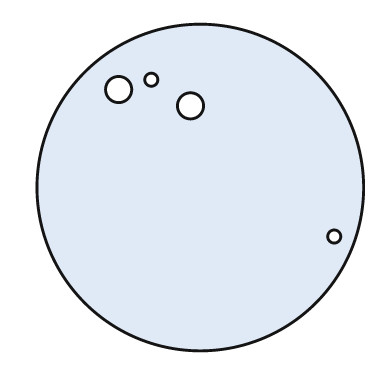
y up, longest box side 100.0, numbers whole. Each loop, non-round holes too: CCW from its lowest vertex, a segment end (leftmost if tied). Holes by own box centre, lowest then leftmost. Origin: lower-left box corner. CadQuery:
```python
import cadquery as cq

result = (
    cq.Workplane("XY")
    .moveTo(50.0, 50.0)
    .circle(50.0)
    .moveTo(91.0, 35.0)
    .circle(2.0)
    .moveTo(47.0, 75.0)
    .circle(4.0)
    .moveTo(25.0, 80.0)
    .circle(4.0)
    .moveTo(35.0, 83.0)
    .circle(2.0)
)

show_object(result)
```